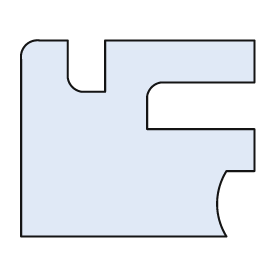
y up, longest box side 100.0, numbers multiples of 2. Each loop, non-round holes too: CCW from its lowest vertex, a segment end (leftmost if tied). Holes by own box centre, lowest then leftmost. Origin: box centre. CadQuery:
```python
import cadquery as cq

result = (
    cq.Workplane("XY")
    .moveTo(-50.0, -42.0)
    .lineTo(38.0, -42.0)
    .threePointArc((34.0, -28.0), (38.0, -14.0))
    .lineTo(50.0, -14.0)
    .lineTo(50.0, 4.0)
    .lineTo(4.0, 4.0)
    .lineTo(4.0, 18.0)
    .threePointArc((6.0, 22.0), (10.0, 24.0))
    .lineTo(50.0, 24.0)
    .lineTo(50.0, 42.0)
    .lineTo(-14.0, 42.0)
    .lineTo(-14.0, 20.0)
    .lineTo(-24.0, 20.0)
    .threePointArc((-28.0, 22.0), (-30.0, 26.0))
    .lineTo(-30.0, 42.0)
    .lineTo(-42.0, 42.0)
    .threePointArc((-48.0, 40.0), (-50.0, 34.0))
    .close()
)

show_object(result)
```